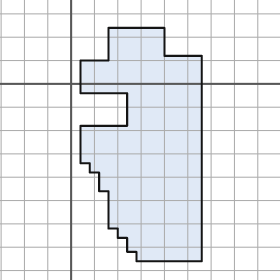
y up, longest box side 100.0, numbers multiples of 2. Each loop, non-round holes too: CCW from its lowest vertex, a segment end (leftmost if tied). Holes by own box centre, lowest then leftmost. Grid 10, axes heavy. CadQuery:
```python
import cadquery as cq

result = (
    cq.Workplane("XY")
    .moveTo(28.0, -76.0)
    .lineTo(56.0, -76.0)
    .lineTo(56.0, 12.0)
    .lineTo(40.0, 12.0)
    .lineTo(40.0, 24.0)
    .lineTo(16.0, 24.0)
    .lineTo(16.0, 10.0)
    .lineTo(4.0, 10.0)
    .lineTo(4.0, -4.0)
    .lineTo(24.0, -4.0)
    .lineTo(24.0, -18.0)
    .lineTo(4.0, -18.0)
    .lineTo(4.0, -34.0)
    .lineTo(8.0, -34.0)
    .lineTo(8.0, -38.0)
    .lineTo(12.0, -38.0)
    .lineTo(12.0, -46.0)
    .lineTo(16.0, -46.0)
    .lineTo(16.0, -62.0)
    .lineTo(20.0, -62.0)
    .lineTo(20.0, -66.0)
    .lineTo(24.0, -66.0)
    .lineTo(24.0, -72.0)
    .lineTo(28.0, -72.0)
    .close()
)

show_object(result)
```